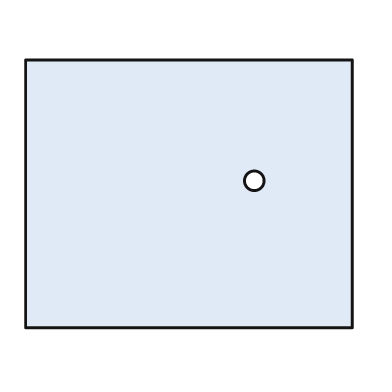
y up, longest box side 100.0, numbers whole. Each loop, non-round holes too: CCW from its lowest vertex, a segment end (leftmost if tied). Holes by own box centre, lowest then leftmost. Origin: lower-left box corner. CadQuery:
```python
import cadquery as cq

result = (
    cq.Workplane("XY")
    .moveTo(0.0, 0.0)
    .lineTo(100.0, 0.0)
    .lineTo(100.0, 82.0)
    .lineTo(0.0, 82.0)
    .close()
    .moveTo(70.0, 45.0)
    .circle(3.0)
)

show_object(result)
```